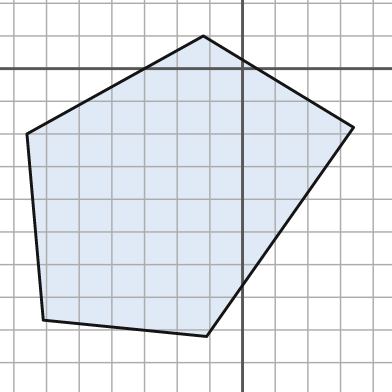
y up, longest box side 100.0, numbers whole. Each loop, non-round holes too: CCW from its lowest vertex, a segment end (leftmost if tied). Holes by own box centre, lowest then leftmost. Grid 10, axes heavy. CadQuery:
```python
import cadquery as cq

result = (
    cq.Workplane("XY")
    .moveTo(-11.0, -82.0)
    .lineTo(34.0, -18.0)
    .lineTo(-12.0, 10.0)
    .lineTo(-66.0, -20.0)
    .lineTo(-61.0, -77.0)
    .close()
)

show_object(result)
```